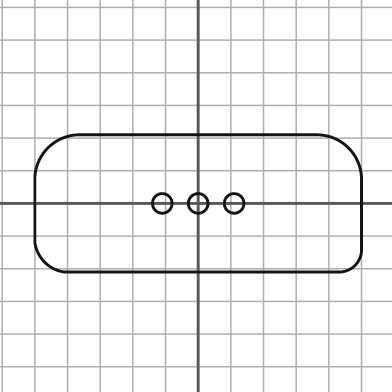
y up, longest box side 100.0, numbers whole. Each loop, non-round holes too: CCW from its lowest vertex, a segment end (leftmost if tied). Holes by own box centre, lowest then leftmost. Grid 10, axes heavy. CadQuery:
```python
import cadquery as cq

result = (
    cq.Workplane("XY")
    .moveTo(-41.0, -21.0)
    .lineTo(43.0, -21.0)
    .threePointArc((48.0, -19.0), (50.0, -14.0))
    .lineTo(50.0, 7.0)
    .threePointArc((46.0, 17.0), (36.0, 21.0))
    .lineTo(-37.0, 21.0)
    .threePointArc((-46.0, 17.0), (-50.0, 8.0))
    .lineTo(-50.0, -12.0)
    .threePointArc((-47.0, -18.0), (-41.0, -21.0))
    .close()
    .moveTo(-11.0, 0.0)
    .circle(3.0)
    .moveTo(0.0, 0.0)
    .circle(3.0)
    .moveTo(11.0, 0.0)
    .circle(3.0)
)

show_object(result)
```